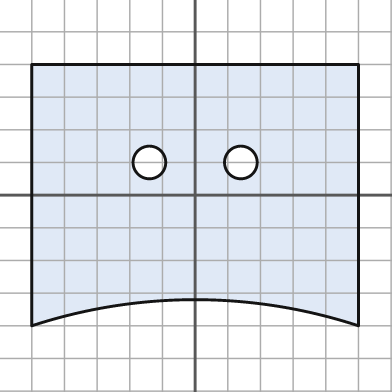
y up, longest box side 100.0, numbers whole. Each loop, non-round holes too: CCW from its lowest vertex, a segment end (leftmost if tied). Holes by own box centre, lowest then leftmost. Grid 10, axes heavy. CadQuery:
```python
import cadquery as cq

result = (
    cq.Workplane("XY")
    .moveTo(-50.0, -40.0)
    .threePointArc((0.0, -32.0), (50.0, -40.0))
    .lineTo(50.0, 40.0)
    .lineTo(-50.0, 40.0)
    .close()
    .moveTo(-14.0, 10.0)
    .circle(5.0)
    .moveTo(14.0, 10.0)
    .circle(5.0)
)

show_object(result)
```